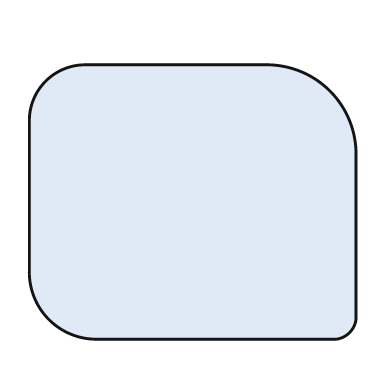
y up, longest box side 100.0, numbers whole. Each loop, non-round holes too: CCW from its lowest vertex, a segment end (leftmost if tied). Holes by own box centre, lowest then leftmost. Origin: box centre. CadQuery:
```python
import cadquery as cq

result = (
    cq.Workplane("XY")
    .moveTo(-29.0, -42.0)
    .lineTo(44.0, -42.0)
    .threePointArc((48.0, -40.0), (50.0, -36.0))
    .lineTo(50.0, 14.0)
    .threePointArc((42.0, 34.0), (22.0, 42.0))
    .lineTo(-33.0, 42.0)
    .threePointArc((-45.0, 37.0), (-50.0, 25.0))
    .lineTo(-50.0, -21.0)
    .threePointArc((-44.0, -36.0), (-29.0, -42.0))
    .close()
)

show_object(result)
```